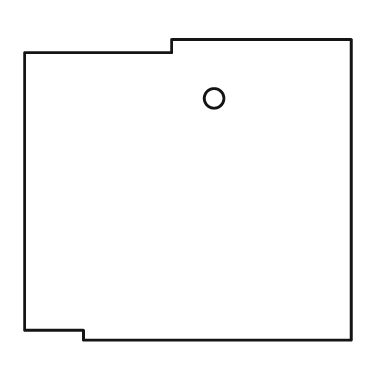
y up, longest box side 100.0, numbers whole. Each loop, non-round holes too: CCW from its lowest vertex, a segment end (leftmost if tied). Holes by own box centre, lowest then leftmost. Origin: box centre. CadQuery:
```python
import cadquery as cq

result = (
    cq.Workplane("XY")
    .moveTo(-32.0, -46.0)
    .lineTo(50.0, -46.0)
    .lineTo(50.0, 46.0)
    .lineTo(-5.0, 46.0)
    .lineTo(-5.0, 42.0)
    .lineTo(-50.0, 42.0)
    .lineTo(-50.0, -43.0)
    .lineTo(-32.0, -43.0)
    .close()
    .moveTo(8.0, 28.0)
    .circle(3.0)
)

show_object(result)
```